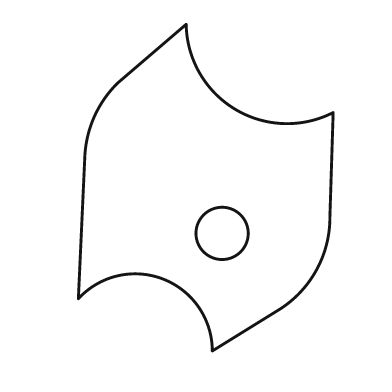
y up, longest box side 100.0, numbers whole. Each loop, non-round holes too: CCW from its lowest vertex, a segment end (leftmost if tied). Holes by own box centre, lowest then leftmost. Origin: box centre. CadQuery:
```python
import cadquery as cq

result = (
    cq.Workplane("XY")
    .moveTo(2.0, -50.0)
    .lineTo(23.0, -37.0)
    .threePointArc((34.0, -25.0), (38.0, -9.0))
    .lineTo(39.0, 23.0)
    .threePointArc((9.0, 24.0), (-6.0, 50.0))
    .lineTo(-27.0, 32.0)
    .threePointArc((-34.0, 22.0), (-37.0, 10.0))
    .lineTo(-39.0, -34.0)
    .threePointArc((-13.0, -28.0), (2.0, -50.0))
    .close()
    .moveTo(5.0, -14.0)
    .circle(8.0)
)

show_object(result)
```